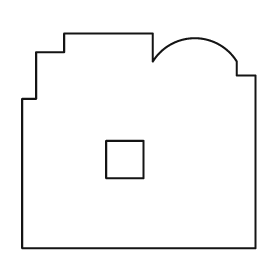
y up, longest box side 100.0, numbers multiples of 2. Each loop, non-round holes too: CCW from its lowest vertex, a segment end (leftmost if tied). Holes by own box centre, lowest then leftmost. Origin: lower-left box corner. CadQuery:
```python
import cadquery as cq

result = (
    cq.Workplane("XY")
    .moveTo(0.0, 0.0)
    .lineTo(100.0, 0.0)
    .lineTo(100.0, 74.0)
    .lineTo(92.0, 74.0)
    .lineTo(92.0, 80.0)
    .threePointArc((74.0, 90.0), (56.0, 80.0))
    .lineTo(56.0, 92.0)
    .lineTo(18.0, 92.0)
    .lineTo(18.0, 84.0)
    .lineTo(6.0, 84.0)
    .lineTo(6.0, 64.0)
    .lineTo(0.0, 64.0)
    .close()
    .moveTo(36.0, 30.0)
    .lineTo(52.0, 30.0)
    .lineTo(52.0, 46.0)
    .lineTo(36.0, 46.0)
    .close()
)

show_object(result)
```